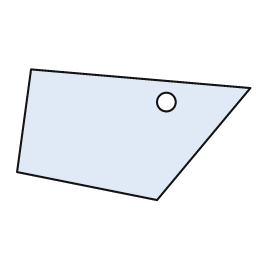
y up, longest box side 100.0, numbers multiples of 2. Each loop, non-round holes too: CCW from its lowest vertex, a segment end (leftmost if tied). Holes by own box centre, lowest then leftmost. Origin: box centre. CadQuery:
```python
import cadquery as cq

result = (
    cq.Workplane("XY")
    .moveTo(10.0, -28.0)
    .lineTo(50.0, 20.0)
    .lineTo(-44.0, 28.0)
    .lineTo(-50.0, -16.0)
    .close()
    .moveTo(14.0, 14.0)
    .circle(4.0)
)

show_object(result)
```